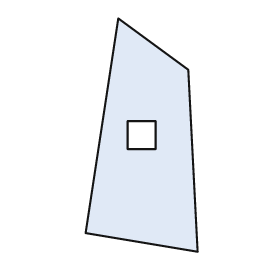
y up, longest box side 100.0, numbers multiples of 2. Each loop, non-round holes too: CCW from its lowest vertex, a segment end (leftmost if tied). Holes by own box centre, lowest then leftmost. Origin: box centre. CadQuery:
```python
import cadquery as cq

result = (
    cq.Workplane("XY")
    .moveTo(24.0, -50.0)
    .lineTo(20.0, 28.0)
    .lineTo(-10.0, 50.0)
    .lineTo(-24.0, -42.0)
    .close()
    .moveTo(-6.0, -6.0)
    .lineTo(6.0, -6.0)
    .lineTo(6.0, 6.0)
    .lineTo(-6.0, 6.0)
    .close()
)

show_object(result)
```